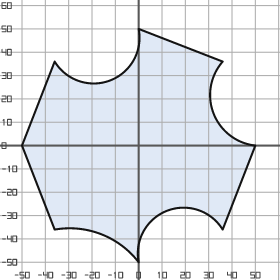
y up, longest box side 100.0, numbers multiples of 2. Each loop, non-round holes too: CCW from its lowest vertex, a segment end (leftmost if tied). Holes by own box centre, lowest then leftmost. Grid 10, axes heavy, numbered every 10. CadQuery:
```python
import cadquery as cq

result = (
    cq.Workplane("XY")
    .moveTo(0.0, -50.0)
    .threePointArc((12.0, -28.0), (36.0, -36.0))
    .lineTo(50.0, 0.0)
    .threePointArc((32.0, 14.0), (36.0, 36.0))
    .lineTo(0.0, 50.0)
    .threePointArc((-12.0, 28.0), (-36.0, 36.0))
    .lineTo(-50.0, 0.0)
    .lineTo(-36.0, -36.0)
    .threePointArc((-16.0, -38.0), (0.0, -50.0))
    .close()
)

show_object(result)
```